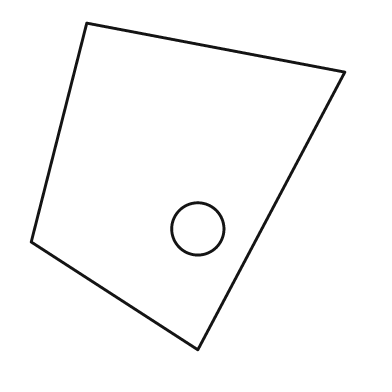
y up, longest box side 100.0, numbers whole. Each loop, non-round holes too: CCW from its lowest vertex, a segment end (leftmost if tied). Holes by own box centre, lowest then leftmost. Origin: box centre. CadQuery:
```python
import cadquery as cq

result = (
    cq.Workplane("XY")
    .moveTo(3.0, -50.0)
    .lineTo(48.0, 35.0)
    .lineTo(-31.0, 50.0)
    .lineTo(-48.0, -17.0)
    .close()
    .moveTo(3.0, -13.0)
    .circle(8.0)
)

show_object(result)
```